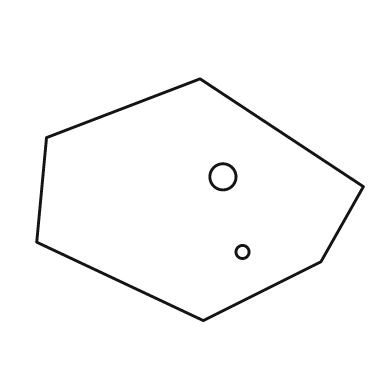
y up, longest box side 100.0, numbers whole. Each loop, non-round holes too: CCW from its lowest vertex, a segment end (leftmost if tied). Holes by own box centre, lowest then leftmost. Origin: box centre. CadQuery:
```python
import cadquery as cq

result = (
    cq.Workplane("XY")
    .moveTo(1.0, -37.0)
    .lineTo(37.0, -19.0)
    .lineTo(50.0, 4.0)
    .lineTo(0.0, 37.0)
    .lineTo(-47.0, 19.0)
    .lineTo(-50.0, -13.0)
    .close()
    .moveTo(13.0, -16.0)
    .circle(2.0)
    .moveTo(7.0, 7.0)
    .circle(4.0)
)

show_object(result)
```